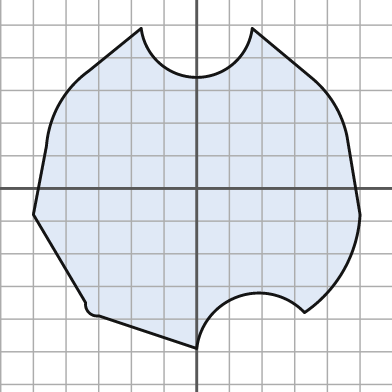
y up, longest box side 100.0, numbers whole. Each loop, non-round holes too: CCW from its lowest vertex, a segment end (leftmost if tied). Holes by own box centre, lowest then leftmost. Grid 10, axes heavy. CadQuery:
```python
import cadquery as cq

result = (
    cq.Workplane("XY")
    .moveTo(0.0, -49.0)
    .threePointArc((13.0, -33.0), (33.0, -38.0))
    .threePointArc((45.0, -25.0), (50.0, -8.0))
    .lineTo(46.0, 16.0)
    .threePointArc((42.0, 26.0), (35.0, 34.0))
    .lineTo(17.0, 49.0)
    .threePointArc((0.0, 34.0), (-17.0, 49.0))
    .lineTo(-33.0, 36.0)
    .threePointArc((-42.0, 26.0), (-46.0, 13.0))
    .lineTo(-50.0, -8.0)
    .lineTo(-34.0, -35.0)
    .threePointArc((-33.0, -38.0), (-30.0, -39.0))
    .close()
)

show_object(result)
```